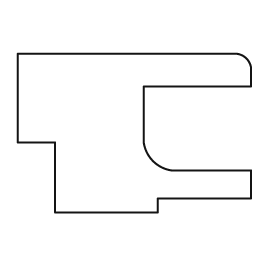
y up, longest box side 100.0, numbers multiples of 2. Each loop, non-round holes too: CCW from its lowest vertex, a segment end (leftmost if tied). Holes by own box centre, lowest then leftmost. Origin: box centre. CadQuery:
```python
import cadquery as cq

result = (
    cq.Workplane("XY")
    .moveTo(-34.0, -34.0)
    .lineTo(10.0, -34.0)
    .lineTo(10.0, -28.0)
    .lineTo(50.0, -28.0)
    .lineTo(50.0, -16.0)
    .lineTo(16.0, -16.0)
    .threePointArc((8.0, -12.0), (4.0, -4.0))
    .lineTo(4.0, 20.0)
    .lineTo(50.0, 20.0)
    .lineTo(50.0, 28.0)
    .threePointArc((48.0, 32.0), (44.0, 34.0))
    .lineTo(-50.0, 34.0)
    .lineTo(-50.0, -4.0)
    .lineTo(-34.0, -4.0)
    .close()
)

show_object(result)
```